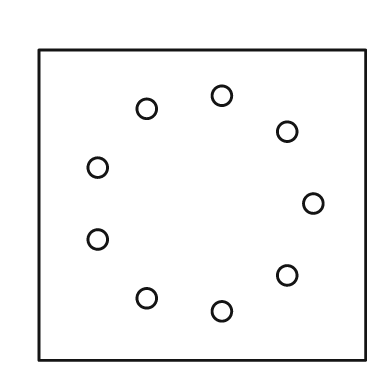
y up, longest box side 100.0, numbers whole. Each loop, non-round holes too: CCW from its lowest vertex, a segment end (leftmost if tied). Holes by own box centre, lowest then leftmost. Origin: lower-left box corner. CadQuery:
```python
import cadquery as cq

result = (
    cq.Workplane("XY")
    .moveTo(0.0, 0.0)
    .lineTo(100.0, 0.0)
    .lineTo(100.0, 95.0)
    .lineTo(0.0, 95.0)
    .close()
    .moveTo(56.0, 15.0)
    .circle(3.0)
    .moveTo(33.0, 19.0)
    .circle(3.0)
    .moveTo(76.0, 26.0)
    .circle(3.0)
    .moveTo(18.0, 37.0)
    .circle(3.0)
    .moveTo(84.0, 48.0)
    .circle(3.0)
    .moveTo(18.0, 59.0)
    .circle(3.0)
    .moveTo(76.0, 70.0)
    .circle(3.0)
    .moveTo(33.0, 77.0)
    .circle(3.0)
    .moveTo(56.0, 81.0)
    .circle(3.0)
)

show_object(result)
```